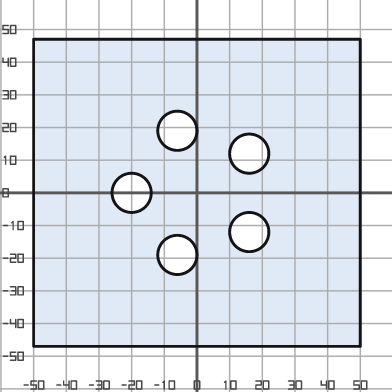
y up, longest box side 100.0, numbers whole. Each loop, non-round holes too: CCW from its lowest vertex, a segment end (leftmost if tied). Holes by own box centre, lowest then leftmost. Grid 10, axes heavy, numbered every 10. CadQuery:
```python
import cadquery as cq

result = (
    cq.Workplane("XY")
    .moveTo(-50.0, -47.0)
    .lineTo(50.0, -47.0)
    .lineTo(50.0, 47.0)
    .lineTo(-50.0, 47.0)
    .close()
    .moveTo(-6.0, -19.0)
    .circle(6.0)
    .moveTo(16.0, -12.0)
    .circle(6.0)
    .moveTo(-20.0, 0.0)
    .circle(6.0)
    .moveTo(16.0, 12.0)
    .circle(6.0)
    .moveTo(-6.0, 19.0)
    .circle(6.0)
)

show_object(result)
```